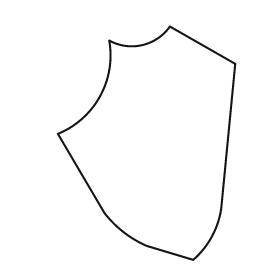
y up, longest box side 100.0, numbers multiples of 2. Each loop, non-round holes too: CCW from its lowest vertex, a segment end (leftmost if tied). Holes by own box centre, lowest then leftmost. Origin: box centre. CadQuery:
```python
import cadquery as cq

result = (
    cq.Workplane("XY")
    .moveTo(20.0, -50.0)
    .threePointArc((28.0, -40.0), (32.0, -28.0))
    .lineTo(38.0, 34.0)
    .lineTo(10.0, 50.0)
    .threePointArc((-2.0, 42.0), (-16.0, 44.0))
    .threePointArc((-20.0, 20.0), (-38.0, 4.0))
    .lineTo(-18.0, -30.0)
    .threePointArc((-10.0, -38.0), (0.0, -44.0))
    .close()
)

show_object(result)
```